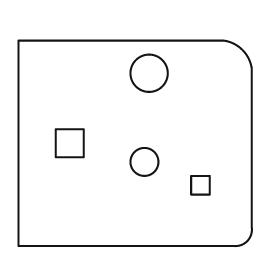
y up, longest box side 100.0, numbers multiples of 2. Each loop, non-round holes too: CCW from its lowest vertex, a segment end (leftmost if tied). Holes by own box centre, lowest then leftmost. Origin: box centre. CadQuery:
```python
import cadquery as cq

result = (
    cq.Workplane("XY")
    .moveTo(-50.0, -44.0)
    .lineTo(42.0, -44.0)
    .threePointArc((48.0, -42.0), (50.0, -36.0))
    .lineTo(50.0, 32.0)
    .threePointArc((46.0, 40.0), (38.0, 44.0))
    .lineTo(-50.0, 44.0)
    .close()
    .moveTo(24.0, -22.0)
    .lineTo(32.0, -22.0)
    .lineTo(32.0, -14.0)
    .lineTo(24.0, -14.0)
    .close()
    .moveTo(4.0, -8.0)
    .circle(6.0)
    .moveTo(-34.0, -6.0)
    .lineTo(-22.0, -6.0)
    .lineTo(-22.0, 6.0)
    .lineTo(-34.0, 6.0)
    .close()
    .moveTo(6.0, 30.0)
    .circle(8.0)
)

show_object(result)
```